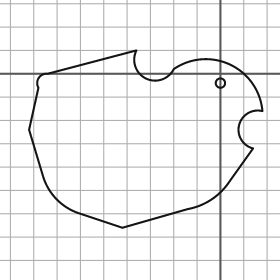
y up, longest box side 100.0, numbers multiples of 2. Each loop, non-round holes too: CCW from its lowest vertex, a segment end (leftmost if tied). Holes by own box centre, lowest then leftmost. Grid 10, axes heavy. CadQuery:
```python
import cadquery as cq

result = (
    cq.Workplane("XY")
    .moveTo(-42.0, -66.0)
    .lineTo(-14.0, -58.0)
    .threePointArc((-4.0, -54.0), (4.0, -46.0))
    .lineTo(14.0, -32.0)
    .threePointArc((8.0, -22.0), (18.0, -16.0))
    .threePointArc((4.0, 4.0), (-20.0, 2.0))
    .threePointArc((-32.0, -2.0), (-36.0, 10.0))
    .lineTo(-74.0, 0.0)
    .threePointArc((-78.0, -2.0), (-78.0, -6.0))
    .lineTo(-82.0, -24.0)
    .lineTo(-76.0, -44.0)
    .threePointArc((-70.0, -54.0), (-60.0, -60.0))
    .close()
    .moveTo(0.0, -4.0)
    .circle(2.0)
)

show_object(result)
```